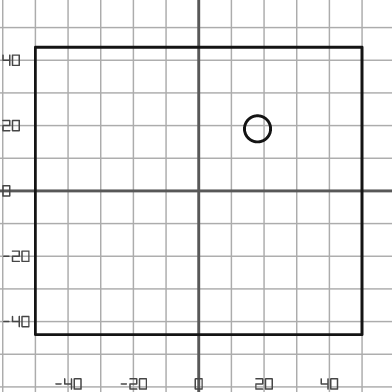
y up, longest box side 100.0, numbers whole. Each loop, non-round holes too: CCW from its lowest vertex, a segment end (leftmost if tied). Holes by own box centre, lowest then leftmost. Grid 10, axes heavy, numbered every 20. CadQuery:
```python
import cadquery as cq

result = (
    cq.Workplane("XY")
    .moveTo(-50.0, -44.0)
    .lineTo(50.0, -44.0)
    .lineTo(50.0, 44.0)
    .lineTo(-50.0, 44.0)
    .close()
    .moveTo(18.0, 19.0)
    .circle(4.0)
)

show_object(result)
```